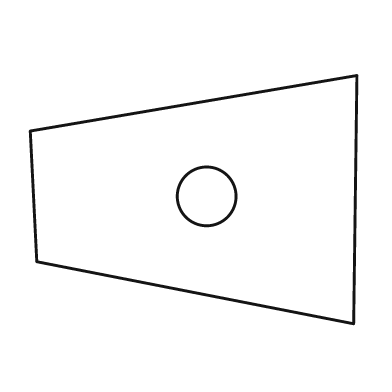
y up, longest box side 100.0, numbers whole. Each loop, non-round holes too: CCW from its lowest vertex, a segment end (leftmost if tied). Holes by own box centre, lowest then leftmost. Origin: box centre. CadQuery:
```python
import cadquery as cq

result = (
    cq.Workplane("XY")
    .moveTo(49.0, -38.0)
    .lineTo(50.0, 38.0)
    .lineTo(-50.0, 21.0)
    .lineTo(-48.0, -19.0)
    .close()
    .moveTo(4.0, 1.0)
    .circle(9.0)
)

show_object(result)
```